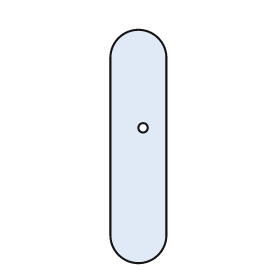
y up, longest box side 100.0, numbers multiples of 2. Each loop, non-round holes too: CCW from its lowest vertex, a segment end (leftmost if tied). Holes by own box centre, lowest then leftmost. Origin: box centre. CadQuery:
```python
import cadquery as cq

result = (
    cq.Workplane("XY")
    .moveTo(-12.0, -38.0)
    .threePointArc((0.0, -50.0), (12.0, -38.0))
    .lineTo(12.0, 38.0)
    .threePointArc((0.0, 50.0), (-12.0, 38.0))
    .close()
    .moveTo(2.0, 8.0)
    .circle(2.0)
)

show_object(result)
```